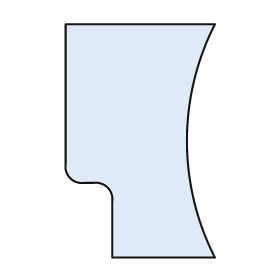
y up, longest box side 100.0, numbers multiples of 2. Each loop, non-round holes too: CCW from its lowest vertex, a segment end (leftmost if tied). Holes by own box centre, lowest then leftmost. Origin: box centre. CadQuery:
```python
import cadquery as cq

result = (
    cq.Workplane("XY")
    .moveTo(-12.0, -50.0)
    .lineTo(32.0, -50.0)
    .threePointArc((20.0, 0.0), (32.0, 50.0))
    .lineTo(-32.0, 50.0)
    .lineTo(-32.0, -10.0)
    .threePointArc((-30.0, -16.0), (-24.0, -18.0))
    .lineTo(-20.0, -18.0)
    .threePointArc((-14.0, -20.0), (-12.0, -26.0))
    .close()
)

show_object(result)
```